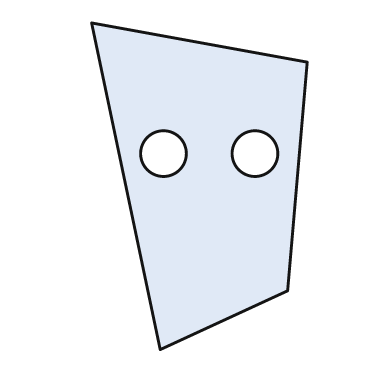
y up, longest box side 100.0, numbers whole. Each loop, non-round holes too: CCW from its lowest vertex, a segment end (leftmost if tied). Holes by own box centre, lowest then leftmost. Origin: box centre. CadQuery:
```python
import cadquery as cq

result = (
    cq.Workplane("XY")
    .moveTo(-12.0, -50.0)
    .lineTo(27.0, -32.0)
    .lineTo(33.0, 38.0)
    .lineTo(-33.0, 50.0)
    .close()
    .moveTo(-11.0, 10.0)
    .circle(7.0)
    .moveTo(17.0, 10.0)
    .circle(7.0)
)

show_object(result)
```